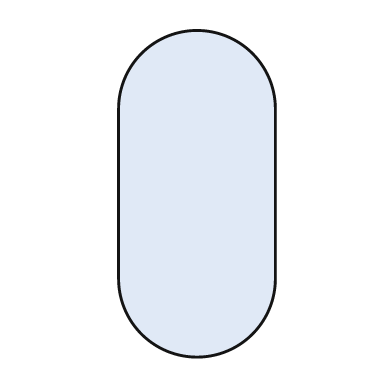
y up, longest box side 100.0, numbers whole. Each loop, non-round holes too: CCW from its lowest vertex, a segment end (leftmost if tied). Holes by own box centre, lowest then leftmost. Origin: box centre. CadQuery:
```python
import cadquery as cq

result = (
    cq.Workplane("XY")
    .moveTo(-24.0, -26.0)
    .threePointArc((0.0, -50.0), (24.0, -26.0))
    .lineTo(24.0, 26.0)
    .threePointArc((0.0, 50.0), (-24.0, 26.0))
    .close()
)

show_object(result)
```